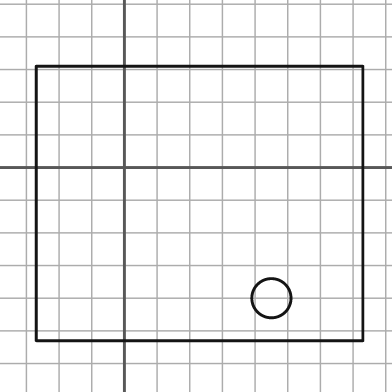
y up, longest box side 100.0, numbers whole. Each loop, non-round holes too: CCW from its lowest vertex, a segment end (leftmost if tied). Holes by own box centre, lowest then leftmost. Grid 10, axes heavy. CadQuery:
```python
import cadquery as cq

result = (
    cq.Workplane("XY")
    .moveTo(-27.0, -53.0)
    .lineTo(73.0, -53.0)
    .lineTo(73.0, 31.0)
    .lineTo(-27.0, 31.0)
    .close()
    .moveTo(45.0, -40.0)
    .circle(6.0)
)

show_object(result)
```